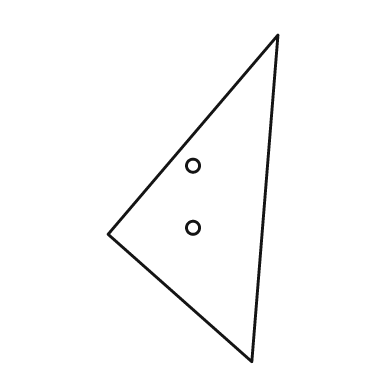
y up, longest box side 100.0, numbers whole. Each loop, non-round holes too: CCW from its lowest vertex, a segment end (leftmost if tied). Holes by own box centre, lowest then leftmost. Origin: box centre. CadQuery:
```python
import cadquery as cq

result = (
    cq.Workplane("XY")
    .moveTo(18.0, -50.0)
    .lineTo(26.0, 50.0)
    .lineTo(-26.0, -11.0)
    .close()
    .moveTo(0.0, -9.0)
    .circle(2.0)
    .moveTo(0.0, 10.0)
    .circle(2.0)
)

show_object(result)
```